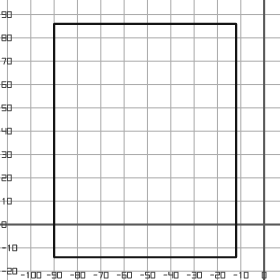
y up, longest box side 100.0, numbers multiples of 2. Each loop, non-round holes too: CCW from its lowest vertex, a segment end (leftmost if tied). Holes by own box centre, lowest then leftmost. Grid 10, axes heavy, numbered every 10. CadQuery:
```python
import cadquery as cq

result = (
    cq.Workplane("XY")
    .moveTo(-90.0, -14.0)
    .lineTo(-12.0, -14.0)
    .lineTo(-12.0, 86.0)
    .lineTo(-90.0, 86.0)
    .close()
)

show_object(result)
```